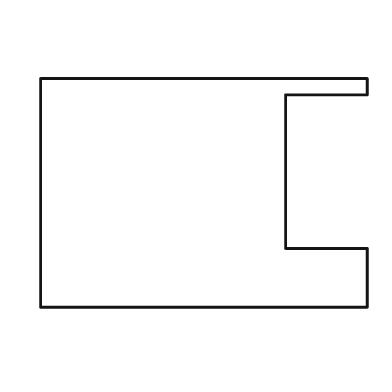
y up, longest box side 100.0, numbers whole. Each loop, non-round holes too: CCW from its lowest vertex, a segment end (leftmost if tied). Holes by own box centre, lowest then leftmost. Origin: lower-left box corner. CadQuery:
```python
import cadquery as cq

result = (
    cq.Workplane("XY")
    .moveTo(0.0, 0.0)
    .lineTo(100.0, 0.0)
    .lineTo(100.0, 18.0)
    .lineTo(75.0, 18.0)
    .lineTo(75.0, 65.0)
    .lineTo(100.0, 65.0)
    .lineTo(100.0, 70.0)
    .lineTo(0.0, 70.0)
    .close()
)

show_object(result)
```